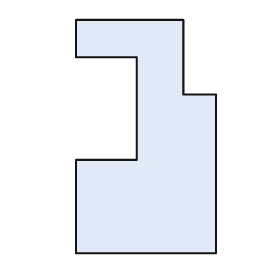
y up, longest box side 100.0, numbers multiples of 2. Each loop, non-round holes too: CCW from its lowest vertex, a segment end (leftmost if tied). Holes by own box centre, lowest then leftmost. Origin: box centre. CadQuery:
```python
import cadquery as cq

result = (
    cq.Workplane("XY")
    .moveTo(-30.0, -50.0)
    .lineTo(30.0, -50.0)
    .lineTo(30.0, 18.0)
    .lineTo(16.0, 18.0)
    .lineTo(16.0, 50.0)
    .lineTo(-30.0, 50.0)
    .lineTo(-30.0, 34.0)
    .lineTo(-4.0, 34.0)
    .lineTo(-4.0, -10.0)
    .lineTo(-30.0, -10.0)
    .close()
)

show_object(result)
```